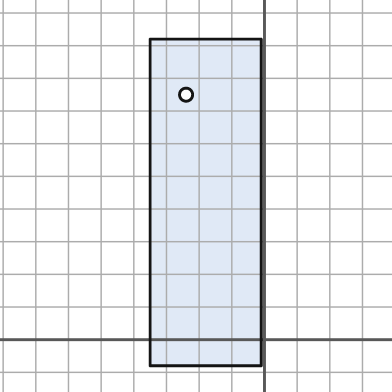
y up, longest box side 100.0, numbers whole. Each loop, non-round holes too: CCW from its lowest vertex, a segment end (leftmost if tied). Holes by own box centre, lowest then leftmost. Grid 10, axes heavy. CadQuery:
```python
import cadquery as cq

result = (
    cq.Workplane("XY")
    .moveTo(-35.0, -8.0)
    .lineTo(-1.0, -8.0)
    .lineTo(-1.0, 92.0)
    .lineTo(-35.0, 92.0)
    .close()
    .moveTo(-24.0, 75.0)
    .circle(2.0)
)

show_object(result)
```